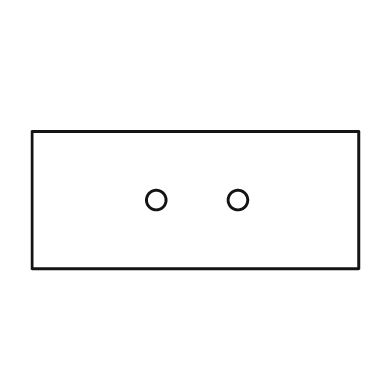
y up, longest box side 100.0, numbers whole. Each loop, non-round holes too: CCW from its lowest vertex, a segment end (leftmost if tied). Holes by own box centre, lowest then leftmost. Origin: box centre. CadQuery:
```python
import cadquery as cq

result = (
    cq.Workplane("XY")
    .moveTo(-50.0, -21.0)
    .lineTo(50.0, -21.0)
    .lineTo(50.0, 21.0)
    .lineTo(-50.0, 21.0)
    .close()
    .moveTo(-12.0, 0.0)
    .circle(3.0)
    .moveTo(13.0, 0.0)
    .circle(3.0)
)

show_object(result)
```